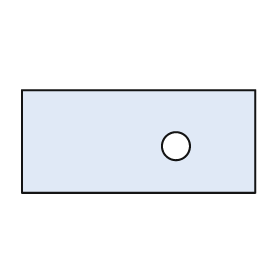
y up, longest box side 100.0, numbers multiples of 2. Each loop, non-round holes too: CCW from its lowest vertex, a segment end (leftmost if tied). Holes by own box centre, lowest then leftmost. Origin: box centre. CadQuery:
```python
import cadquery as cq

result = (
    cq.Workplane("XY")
    .moveTo(-50.0, -22.0)
    .lineTo(50.0, -22.0)
    .lineTo(50.0, 22.0)
    .lineTo(-50.0, 22.0)
    .close()
    .moveTo(16.0, -2.0)
    .circle(6.0)
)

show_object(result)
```